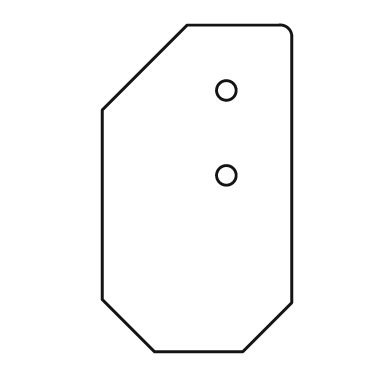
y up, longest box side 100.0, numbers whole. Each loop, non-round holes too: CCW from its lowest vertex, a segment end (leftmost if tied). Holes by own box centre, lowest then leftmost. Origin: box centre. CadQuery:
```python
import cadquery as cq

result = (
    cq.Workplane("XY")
    .moveTo(-13.0, -50.0)
    .lineTo(14.0, -50.0)
    .lineTo(29.0, -35.0)
    .lineTo(29.0, 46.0)
    .threePointArc((28.0, 49.0), (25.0, 50.0))
    .lineTo(-3.0, 50.0)
    .lineTo(-29.0, 24.0)
    .lineTo(-29.0, -34.0)
    .close()
    .moveTo(9.0, 4.0)
    .circle(3.0)
    .moveTo(9.0, 30.0)
    .circle(3.0)
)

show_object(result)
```